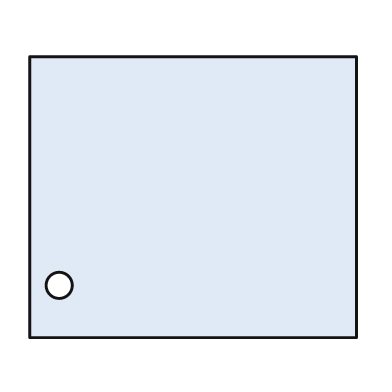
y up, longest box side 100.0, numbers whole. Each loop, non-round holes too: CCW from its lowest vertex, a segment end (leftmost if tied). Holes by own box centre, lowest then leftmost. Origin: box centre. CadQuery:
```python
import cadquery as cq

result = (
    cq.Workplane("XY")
    .moveTo(-50.0, -43.0)
    .lineTo(50.0, -43.0)
    .lineTo(50.0, 43.0)
    .lineTo(-50.0, 43.0)
    .close()
    .moveTo(-41.0, -27.0)
    .circle(4.0)
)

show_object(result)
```